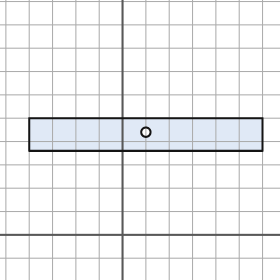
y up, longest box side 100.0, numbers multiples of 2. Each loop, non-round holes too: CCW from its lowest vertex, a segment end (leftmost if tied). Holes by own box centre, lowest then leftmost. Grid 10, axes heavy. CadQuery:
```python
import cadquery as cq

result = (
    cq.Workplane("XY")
    .moveTo(-40.0, 36.0)
    .lineTo(60.0, 36.0)
    .lineTo(60.0, 50.0)
    .lineTo(-40.0, 50.0)
    .close()
    .moveTo(10.0, 44.0)
    .circle(2.0)
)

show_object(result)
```